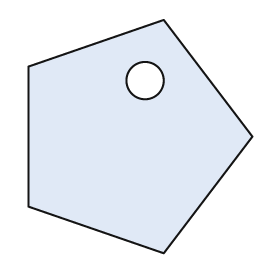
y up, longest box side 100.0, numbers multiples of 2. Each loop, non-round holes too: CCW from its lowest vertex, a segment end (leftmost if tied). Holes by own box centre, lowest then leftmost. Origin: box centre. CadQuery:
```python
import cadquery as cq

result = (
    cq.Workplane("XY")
    .moveTo(10.0, -50.0)
    .lineTo(48.0, 0.0)
    .lineTo(10.0, 50.0)
    .lineTo(-48.0, 30.0)
    .lineTo(-48.0, -30.0)
    .close()
    .moveTo(2.0, 24.0)
    .circle(8.0)
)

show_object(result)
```